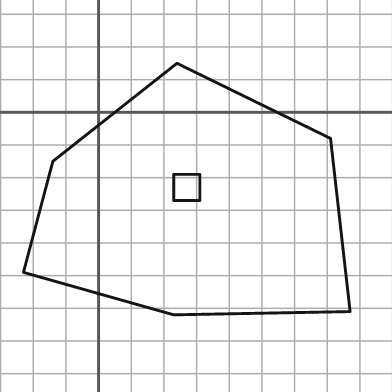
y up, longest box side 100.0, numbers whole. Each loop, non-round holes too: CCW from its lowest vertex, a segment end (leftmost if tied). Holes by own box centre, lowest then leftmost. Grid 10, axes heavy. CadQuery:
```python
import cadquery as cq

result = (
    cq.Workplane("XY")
    .moveTo(23.0, -62.0)
    .lineTo(77.0, -61.0)
    .lineTo(71.0, -8.0)
    .lineTo(24.0, 15.0)
    .lineTo(-14.0, -15.0)
    .lineTo(-23.0, -49.0)
    .close()
    .moveTo(23.0, -27.0)
    .lineTo(31.0, -27.0)
    .lineTo(31.0, -19.0)
    .lineTo(23.0, -19.0)
    .close()
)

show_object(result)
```